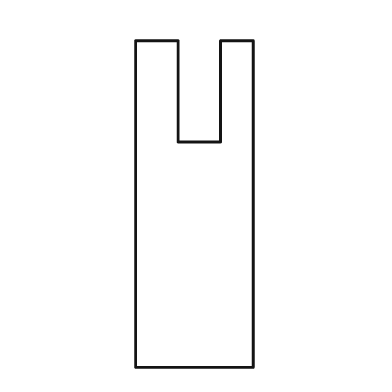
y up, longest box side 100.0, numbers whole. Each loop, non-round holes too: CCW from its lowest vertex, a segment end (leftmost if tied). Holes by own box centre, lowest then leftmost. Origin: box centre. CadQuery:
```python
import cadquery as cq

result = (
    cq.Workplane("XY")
    .moveTo(-18.0, -50.0)
    .lineTo(18.0, -50.0)
    .lineTo(18.0, 50.0)
    .lineTo(8.0, 50.0)
    .lineTo(8.0, 19.0)
    .lineTo(-5.0, 19.0)
    .lineTo(-5.0, 50.0)
    .lineTo(-18.0, 50.0)
    .close()
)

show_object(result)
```